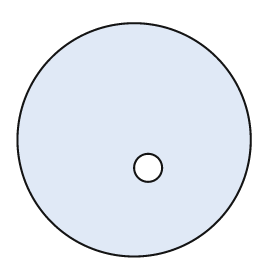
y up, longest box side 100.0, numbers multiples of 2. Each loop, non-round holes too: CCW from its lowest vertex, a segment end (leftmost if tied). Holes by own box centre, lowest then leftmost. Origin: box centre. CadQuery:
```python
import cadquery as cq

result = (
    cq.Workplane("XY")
    .moveTo(0.0, 0.0)
    .circle(50.0)
    .moveTo(6.0, -12.0)
    .circle(6.0)
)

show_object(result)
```